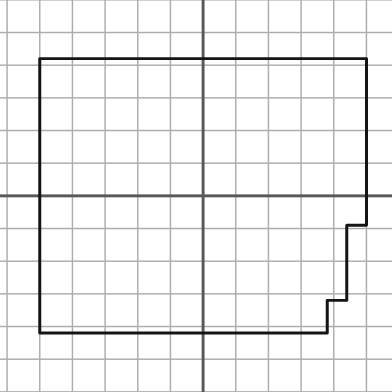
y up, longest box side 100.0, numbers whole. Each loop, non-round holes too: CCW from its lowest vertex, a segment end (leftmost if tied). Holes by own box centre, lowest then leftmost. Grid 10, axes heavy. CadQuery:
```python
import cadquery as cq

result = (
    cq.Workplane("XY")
    .moveTo(-50.0, -42.0)
    .lineTo(38.0, -42.0)
    .lineTo(38.0, -32.0)
    .lineTo(44.0, -32.0)
    .lineTo(44.0, -9.0)
    .lineTo(50.0, -9.0)
    .lineTo(50.0, 42.0)
    .lineTo(-50.0, 42.0)
    .close()
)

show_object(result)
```